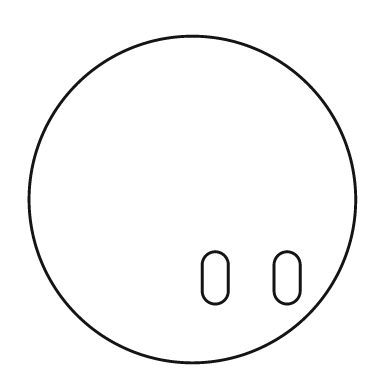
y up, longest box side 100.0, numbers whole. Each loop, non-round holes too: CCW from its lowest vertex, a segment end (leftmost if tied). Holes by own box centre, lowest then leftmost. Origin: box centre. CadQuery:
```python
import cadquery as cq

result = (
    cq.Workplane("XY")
    .moveTo(0.0, 0.0)
    .circle(50.0)
    .moveTo(3.0, -28.0)
    .threePointArc((7.0, -32.0), (11.0, -28.0))
    .lineTo(11.0, -20.0)
    .threePointArc((7.0, -16.0), (3.0, -20.0))
    .close()
    .moveTo(25.0, -28.0)
    .threePointArc((29.0, -32.0), (33.0, -28.0))
    .lineTo(33.0, -20.0)
    .threePointArc((29.0, -16.0), (25.0, -20.0))
    .close()
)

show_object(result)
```